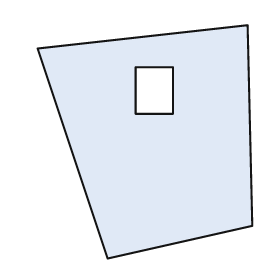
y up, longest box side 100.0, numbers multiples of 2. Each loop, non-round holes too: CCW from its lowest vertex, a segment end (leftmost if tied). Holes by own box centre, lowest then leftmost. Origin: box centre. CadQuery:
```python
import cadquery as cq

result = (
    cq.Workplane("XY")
    .moveTo(-16.0, -50.0)
    .lineTo(46.0, -36.0)
    .lineTo(44.0, 50.0)
    .lineTo(-46.0, 40.0)
    .close()
    .moveTo(-4.0, 12.0)
    .lineTo(12.0, 12.0)
    .lineTo(12.0, 32.0)
    .lineTo(-4.0, 32.0)
    .close()
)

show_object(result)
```